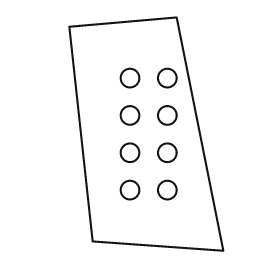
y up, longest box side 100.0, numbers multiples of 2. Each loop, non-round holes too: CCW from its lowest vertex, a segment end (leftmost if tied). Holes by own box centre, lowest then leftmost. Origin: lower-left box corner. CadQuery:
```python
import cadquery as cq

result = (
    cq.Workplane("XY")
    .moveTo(66.0, 0.0)
    .lineTo(46.0, 100.0)
    .lineTo(0.0, 96.0)
    .lineTo(10.0, 4.0)
    .close()
    .moveTo(26.0, 26.0)
    .circle(4.0)
    .moveTo(42.0, 26.0)
    .circle(4.0)
    .moveTo(26.0, 42.0)
    .circle(4.0)
    .moveTo(42.0, 42.0)
    .circle(4.0)
    .moveTo(26.0, 58.0)
    .circle(4.0)
    .moveTo(42.0, 58.0)
    .circle(4.0)
    .moveTo(26.0, 74.0)
    .circle(4.0)
    .moveTo(42.0, 74.0)
    .circle(4.0)
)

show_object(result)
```